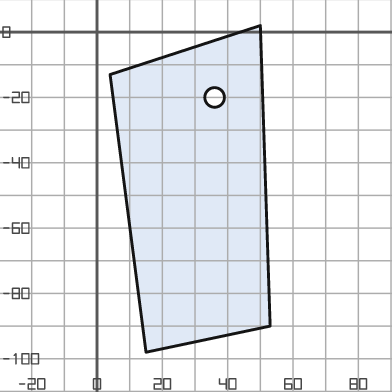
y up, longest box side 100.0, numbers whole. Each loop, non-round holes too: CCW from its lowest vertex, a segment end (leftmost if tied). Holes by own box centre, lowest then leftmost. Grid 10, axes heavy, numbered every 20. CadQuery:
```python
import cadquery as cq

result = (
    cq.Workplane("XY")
    .moveTo(15.0, -98.0)
    .lineTo(53.0, -90.0)
    .lineTo(50.0, 2.0)
    .lineTo(4.0, -13.0)
    .close()
    .moveTo(36.0, -20.0)
    .circle(3.0)
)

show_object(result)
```